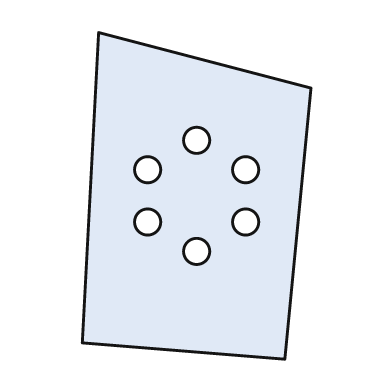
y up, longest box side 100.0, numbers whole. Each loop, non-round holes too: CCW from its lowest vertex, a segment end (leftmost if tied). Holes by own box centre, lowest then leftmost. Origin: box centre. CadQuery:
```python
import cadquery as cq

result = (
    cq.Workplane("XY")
    .moveTo(27.0, -50.0)
    .lineTo(35.0, 33.0)
    .lineTo(-30.0, 50.0)
    .lineTo(-35.0, -45.0)
    .close()
    .moveTo(0.0, -17.0)
    .circle(4.0)
    .moveTo(-15.0, -8.0)
    .circle(4.0)
    .moveTo(15.0, -8.0)
    .circle(4.0)
    .moveTo(-15.0, 8.0)
    .circle(4.0)
    .moveTo(15.0, 8.0)
    .circle(4.0)
    .moveTo(0.0, 17.0)
    .circle(4.0)
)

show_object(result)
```